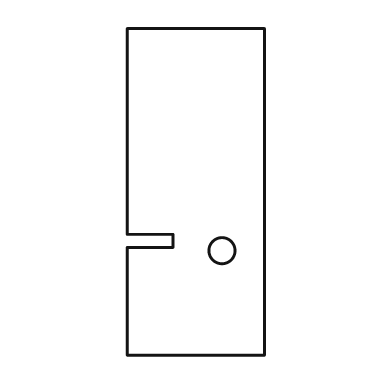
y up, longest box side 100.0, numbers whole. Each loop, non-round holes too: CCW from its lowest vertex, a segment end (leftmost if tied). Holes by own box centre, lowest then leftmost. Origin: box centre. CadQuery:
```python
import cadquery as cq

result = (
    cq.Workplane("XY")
    .moveTo(-21.0, -50.0)
    .lineTo(21.0, -50.0)
    .lineTo(21.0, 50.0)
    .lineTo(-21.0, 50.0)
    .lineTo(-21.0, -13.0)
    .lineTo(-7.0, -13.0)
    .lineTo(-7.0, -17.0)
    .lineTo(-21.0, -17.0)
    .close()
    .moveTo(8.0, -18.0)
    .circle(4.0)
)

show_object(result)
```